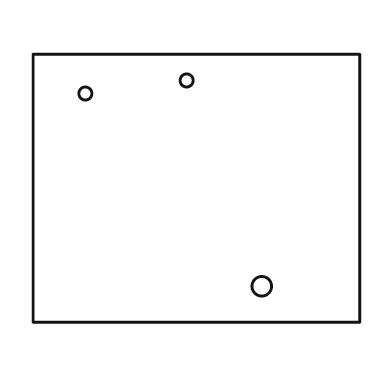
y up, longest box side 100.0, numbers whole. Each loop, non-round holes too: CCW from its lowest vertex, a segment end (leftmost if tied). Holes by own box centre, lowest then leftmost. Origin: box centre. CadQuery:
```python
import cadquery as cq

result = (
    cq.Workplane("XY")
    .moveTo(-50.0, -41.0)
    .lineTo(50.0, -41.0)
    .lineTo(50.0, 41.0)
    .lineTo(-50.0, 41.0)
    .close()
    .moveTo(20.0, -30.0)
    .circle(3.0)
    .moveTo(-34.0, 29.0)
    .circle(2.0)
    .moveTo(-3.0, 33.0)
    .circle(2.0)
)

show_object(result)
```